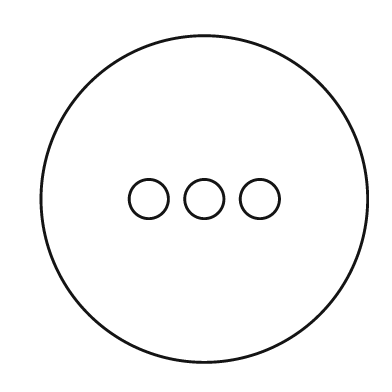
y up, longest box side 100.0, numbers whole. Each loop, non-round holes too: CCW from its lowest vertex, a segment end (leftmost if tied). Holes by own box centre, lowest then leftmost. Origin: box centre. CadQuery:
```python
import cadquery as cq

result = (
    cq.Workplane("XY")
    .moveTo(0.0, 0.0)
    .circle(50.0)
    .moveTo(-17.0, 0.0)
    .circle(6.0)
    .moveTo(0.0, 0.0)
    .circle(6.0)
    .moveTo(17.0, 0.0)
    .circle(6.0)
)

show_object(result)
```